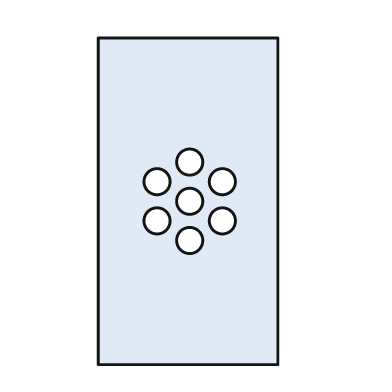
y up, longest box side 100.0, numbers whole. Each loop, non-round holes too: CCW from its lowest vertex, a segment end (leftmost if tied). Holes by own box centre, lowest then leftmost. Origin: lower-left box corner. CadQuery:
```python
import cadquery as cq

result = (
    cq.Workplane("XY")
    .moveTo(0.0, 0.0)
    .lineTo(55.0, 0.0)
    .lineTo(55.0, 100.0)
    .lineTo(0.0, 100.0)
    .close()
    .moveTo(28.0, 38.0)
    .circle(4.0)
    .moveTo(18.0, 44.0)
    .circle(4.0)
    .moveTo(38.0, 44.0)
    .circle(4.0)
    .moveTo(28.0, 50.0)
    .circle(4.0)
    .moveTo(18.0, 56.0)
    .circle(4.0)
    .moveTo(38.0, 56.0)
    .circle(4.0)
    .moveTo(28.0, 62.0)
    .circle(4.0)
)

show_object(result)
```